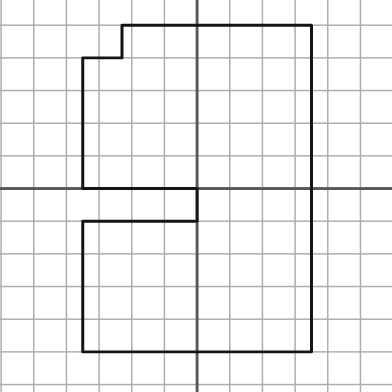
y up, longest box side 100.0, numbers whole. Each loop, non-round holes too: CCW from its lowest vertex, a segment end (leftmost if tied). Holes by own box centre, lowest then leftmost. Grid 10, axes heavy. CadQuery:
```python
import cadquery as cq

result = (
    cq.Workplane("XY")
    .moveTo(-35.0, -50.0)
    .lineTo(35.0, -50.0)
    .lineTo(35.0, 50.0)
    .lineTo(-23.0, 50.0)
    .lineTo(-23.0, 40.0)
    .lineTo(-35.0, 40.0)
    .lineTo(-35.0, 0.0)
    .lineTo(0.0, 0.0)
    .lineTo(0.0, -10.0)
    .lineTo(-35.0, -10.0)
    .close()
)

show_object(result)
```